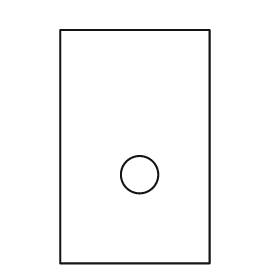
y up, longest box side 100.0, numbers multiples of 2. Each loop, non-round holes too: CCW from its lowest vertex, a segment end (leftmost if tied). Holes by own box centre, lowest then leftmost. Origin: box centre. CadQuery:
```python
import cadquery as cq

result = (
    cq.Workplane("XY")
    .moveTo(-32.0, -50.0)
    .lineTo(32.0, -50.0)
    .lineTo(32.0, 50.0)
    .lineTo(-32.0, 50.0)
    .close()
    .moveTo(2.0, -12.0)
    .circle(8.0)
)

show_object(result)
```